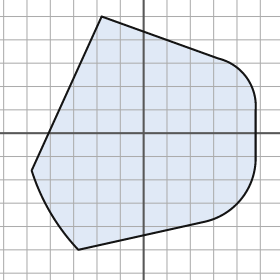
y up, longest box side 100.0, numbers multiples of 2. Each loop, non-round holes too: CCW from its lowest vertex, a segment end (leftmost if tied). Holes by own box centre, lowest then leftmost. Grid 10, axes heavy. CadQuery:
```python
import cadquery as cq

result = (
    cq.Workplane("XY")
    .moveTo(-28.0, -50.0)
    .lineTo(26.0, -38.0)
    .threePointArc((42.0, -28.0), (48.0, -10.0))
    .lineTo(48.0, 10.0)
    .threePointArc((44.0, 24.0), (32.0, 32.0))
    .lineTo(-18.0, 50.0)
    .lineTo(-48.0, -16.0)
    .threePointArc((-40.0, -34.0), (-28.0, -50.0))
    .close()
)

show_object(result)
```